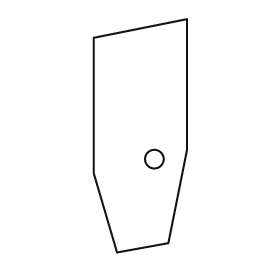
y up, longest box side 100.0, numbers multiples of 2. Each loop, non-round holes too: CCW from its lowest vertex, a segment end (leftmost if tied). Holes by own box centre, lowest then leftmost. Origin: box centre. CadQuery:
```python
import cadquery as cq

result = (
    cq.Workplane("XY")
    .moveTo(-10.0, -50.0)
    .lineTo(12.0, -46.0)
    .lineTo(20.0, -6.0)
    .lineTo(20.0, 50.0)
    .lineTo(-20.0, 42.0)
    .lineTo(-20.0, -16.0)
    .close()
    .moveTo(6.0, -10.0)
    .circle(4.0)
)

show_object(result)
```